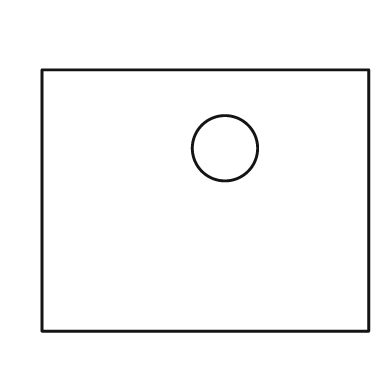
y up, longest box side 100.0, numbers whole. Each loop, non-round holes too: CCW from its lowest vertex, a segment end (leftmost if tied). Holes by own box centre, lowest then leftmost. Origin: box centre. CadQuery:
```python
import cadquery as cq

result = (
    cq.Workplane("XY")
    .moveTo(-50.0, -40.0)
    .lineTo(50.0, -40.0)
    .lineTo(50.0, 40.0)
    .lineTo(-50.0, 40.0)
    .close()
    .moveTo(6.0, 16.0)
    .circle(10.0)
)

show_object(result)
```